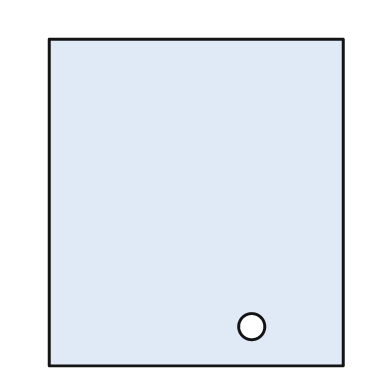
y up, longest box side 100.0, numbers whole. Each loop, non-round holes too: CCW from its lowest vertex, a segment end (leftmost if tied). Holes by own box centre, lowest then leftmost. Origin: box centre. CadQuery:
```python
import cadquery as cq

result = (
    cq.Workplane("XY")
    .moveTo(-45.0, -50.0)
    .lineTo(45.0, -50.0)
    .lineTo(45.0, 50.0)
    .lineTo(-45.0, 50.0)
    .close()
    .moveTo(17.0, -38.0)
    .circle(4.0)
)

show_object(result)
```